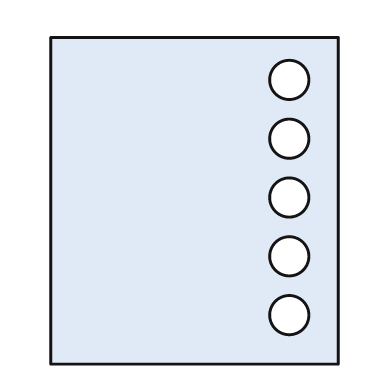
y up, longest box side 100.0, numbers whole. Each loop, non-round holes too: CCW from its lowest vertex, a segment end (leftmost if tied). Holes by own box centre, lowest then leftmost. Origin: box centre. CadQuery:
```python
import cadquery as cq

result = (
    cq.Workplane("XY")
    .moveTo(-44.0, -50.0)
    .lineTo(44.0, -50.0)
    .lineTo(44.0, 50.0)
    .lineTo(-44.0, 50.0)
    .close()
    .moveTo(29.0, -35.0)
    .circle(6.0)
    .moveTo(29.0, -17.0)
    .circle(6.0)
    .moveTo(29.0, 1.0)
    .circle(6.0)
    .moveTo(29.0, 19.0)
    .circle(6.0)
    .moveTo(29.0, 37.0)
    .circle(6.0)
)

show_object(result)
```